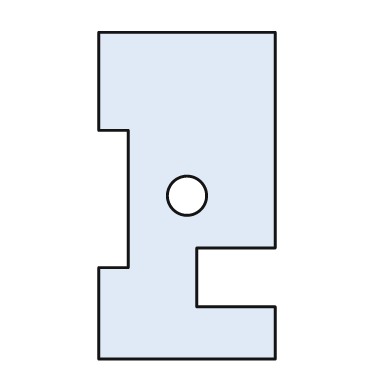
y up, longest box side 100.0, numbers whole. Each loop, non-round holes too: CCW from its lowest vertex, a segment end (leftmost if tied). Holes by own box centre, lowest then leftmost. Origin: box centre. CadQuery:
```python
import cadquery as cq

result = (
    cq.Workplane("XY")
    .moveTo(-27.0, -50.0)
    .lineTo(27.0, -50.0)
    .lineTo(27.0, -34.0)
    .lineTo(3.0, -34.0)
    .lineTo(3.0, -16.0)
    .lineTo(27.0, -16.0)
    .lineTo(27.0, 50.0)
    .lineTo(-27.0, 50.0)
    .lineTo(-27.0, 20.0)
    .lineTo(-18.0, 20.0)
    .lineTo(-18.0, -22.0)
    .lineTo(-27.0, -22.0)
    .close()
    .moveTo(0.0, 0.0)
    .circle(6.0)
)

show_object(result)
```